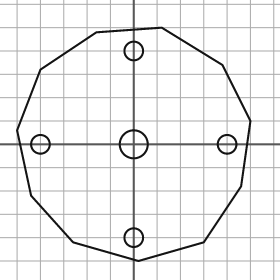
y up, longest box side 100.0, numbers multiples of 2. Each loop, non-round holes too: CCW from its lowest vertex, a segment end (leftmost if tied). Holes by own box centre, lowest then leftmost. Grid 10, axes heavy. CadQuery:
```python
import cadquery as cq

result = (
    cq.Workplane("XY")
    .moveTo(2.0, -50.0)
    .lineTo(30.0, -42.0)
    .lineTo(46.0, -18.0)
    .lineTo(50.0, 10.0)
    .lineTo(38.0, 34.0)
    .lineTo(12.0, 50.0)
    .lineTo(-16.0, 48.0)
    .lineTo(-40.0, 32.0)
    .lineTo(-50.0, 6.0)
    .lineTo(-44.0, -22.0)
    .lineTo(-26.0, -42.0)
    .close()
    .moveTo(0.0, -40.0)
    .circle(4.0)
    .moveTo(-40.0, 0.0)
    .circle(4.0)
    .moveTo(0.0, 0.0)
    .circle(6.0)
    .moveTo(40.0, 0.0)
    .circle(4.0)
    .moveTo(0.0, 40.0)
    .circle(4.0)
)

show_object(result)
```